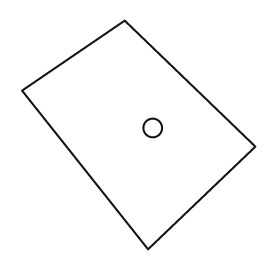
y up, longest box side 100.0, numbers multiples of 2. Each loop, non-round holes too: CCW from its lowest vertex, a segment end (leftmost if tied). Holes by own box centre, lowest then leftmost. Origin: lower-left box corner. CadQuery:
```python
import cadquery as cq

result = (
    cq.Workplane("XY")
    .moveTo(54.0, 0.0)
    .lineTo(100.0, 44.0)
    .lineTo(44.0, 98.0)
    .lineTo(0.0, 68.0)
    .close()
    .moveTo(56.0, 52.0)
    .circle(4.0)
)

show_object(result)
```